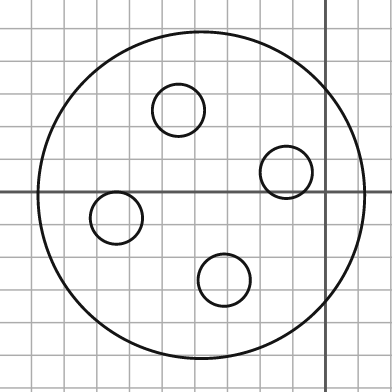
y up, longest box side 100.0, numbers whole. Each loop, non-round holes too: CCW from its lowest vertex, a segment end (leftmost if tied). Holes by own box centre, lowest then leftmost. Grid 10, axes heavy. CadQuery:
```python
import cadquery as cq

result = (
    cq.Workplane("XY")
    .moveTo(-38.0, -1.0)
    .circle(50.0)
    .moveTo(-31.0, -27.0)
    .circle(8.0)
    .moveTo(-64.0, -8.0)
    .circle(8.0)
    .moveTo(-12.0, 6.0)
    .circle(8.0)
    .moveTo(-45.0, 25.0)
    .circle(8.0)
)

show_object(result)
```